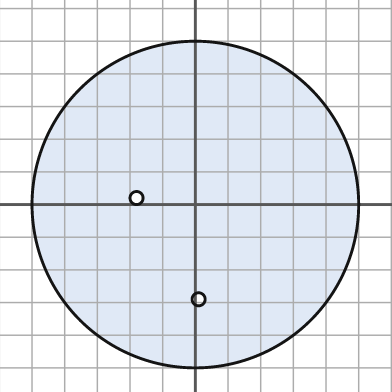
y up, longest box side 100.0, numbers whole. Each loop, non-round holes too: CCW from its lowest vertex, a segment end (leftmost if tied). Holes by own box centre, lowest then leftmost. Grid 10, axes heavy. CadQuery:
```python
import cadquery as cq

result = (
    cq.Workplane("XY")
    .moveTo(0.0, 0.0)
    .circle(50.0)
    .moveTo(1.0, -29.0)
    .circle(2.0)
    .moveTo(-18.0, 2.0)
    .circle(2.0)
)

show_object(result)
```